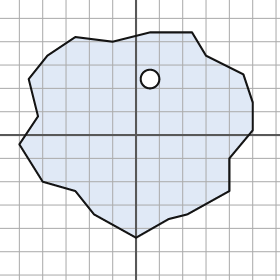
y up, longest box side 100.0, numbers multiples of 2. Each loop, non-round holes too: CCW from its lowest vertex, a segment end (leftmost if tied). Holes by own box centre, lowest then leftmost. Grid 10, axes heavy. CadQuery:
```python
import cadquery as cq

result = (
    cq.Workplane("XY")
    .moveTo(0.0, -44.0)
    .lineTo(14.0, -36.0)
    .lineTo(22.0, -34.0)
    .lineTo(40.0, -24.0)
    .lineTo(40.0, -10.0)
    .lineTo(50.0, 2.0)
    .lineTo(50.0, 14.0)
    .lineTo(46.0, 26.0)
    .lineTo(30.0, 34.0)
    .lineTo(24.0, 44.0)
    .lineTo(6.0, 44.0)
    .lineTo(-10.0, 40.0)
    .lineTo(-26.0, 42.0)
    .lineTo(-38.0, 34.0)
    .lineTo(-46.0, 24.0)
    .lineTo(-42.0, 8.0)
    .lineTo(-50.0, -4.0)
    .lineTo(-40.0, -20.0)
    .lineTo(-26.0, -24.0)
    .lineTo(-18.0, -34.0)
    .close()
    .moveTo(6.0, 24.0)
    .circle(4.0)
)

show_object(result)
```